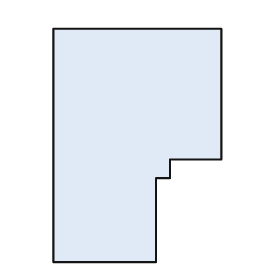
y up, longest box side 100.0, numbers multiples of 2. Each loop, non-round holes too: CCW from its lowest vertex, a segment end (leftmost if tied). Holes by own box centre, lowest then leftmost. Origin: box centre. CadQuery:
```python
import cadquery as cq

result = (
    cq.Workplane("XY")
    .moveTo(-36.0, -50.0)
    .lineTo(8.0, -50.0)
    .lineTo(8.0, -14.0)
    .lineTo(14.0, -14.0)
    .lineTo(14.0, -6.0)
    .lineTo(36.0, -6.0)
    .lineTo(36.0, 50.0)
    .lineTo(-36.0, 50.0)
    .close()
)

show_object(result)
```